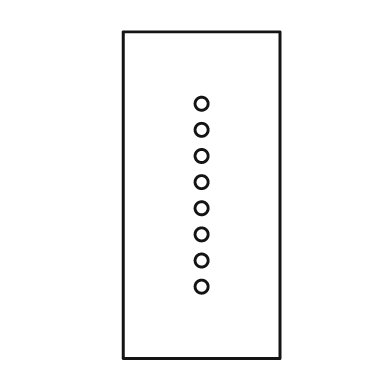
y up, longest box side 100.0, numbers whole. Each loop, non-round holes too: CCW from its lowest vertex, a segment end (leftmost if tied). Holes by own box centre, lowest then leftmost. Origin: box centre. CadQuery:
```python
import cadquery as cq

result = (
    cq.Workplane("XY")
    .moveTo(-24.0, -50.0)
    .lineTo(24.0, -50.0)
    .lineTo(24.0, 50.0)
    .lineTo(-24.0, 50.0)
    .close()
    .moveTo(0.0, -28.0)
    .circle(2.0)
    .moveTo(0.0, -20.0)
    .circle(2.0)
    .moveTo(0.0, -12.0)
    .circle(2.0)
    .moveTo(0.0, -4.0)
    .circle(2.0)
    .moveTo(0.0, 4.0)
    .circle(2.0)
    .moveTo(0.0, 12.0)
    .circle(2.0)
    .moveTo(0.0, 20.0)
    .circle(2.0)
    .moveTo(0.0, 28.0)
    .circle(2.0)
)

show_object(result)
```